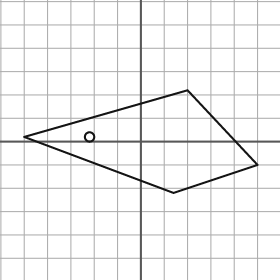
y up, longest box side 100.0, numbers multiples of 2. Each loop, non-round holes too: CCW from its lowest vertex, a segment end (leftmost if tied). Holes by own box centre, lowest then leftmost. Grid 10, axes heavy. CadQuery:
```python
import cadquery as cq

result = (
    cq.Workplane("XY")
    .moveTo(14.0, -22.0)
    .lineTo(50.0, -10.0)
    .lineTo(20.0, 22.0)
    .lineTo(-50.0, 2.0)
    .close()
    .moveTo(-22.0, 2.0)
    .circle(2.0)
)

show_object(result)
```